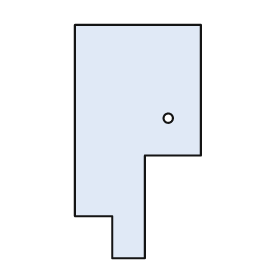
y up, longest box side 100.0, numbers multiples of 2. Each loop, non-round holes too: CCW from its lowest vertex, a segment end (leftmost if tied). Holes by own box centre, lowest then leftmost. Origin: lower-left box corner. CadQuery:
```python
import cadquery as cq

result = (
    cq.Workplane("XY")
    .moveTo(16.0, 0.0)
    .lineTo(30.0, 0.0)
    .lineTo(30.0, 44.0)
    .lineTo(54.0, 44.0)
    .lineTo(54.0, 100.0)
    .lineTo(0.0, 100.0)
    .lineTo(0.0, 18.0)
    .lineTo(16.0, 18.0)
    .close()
    .moveTo(40.0, 60.0)
    .circle(2.0)
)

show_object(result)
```